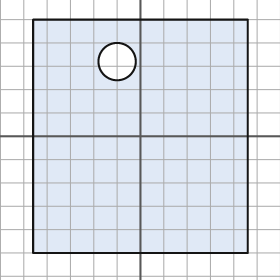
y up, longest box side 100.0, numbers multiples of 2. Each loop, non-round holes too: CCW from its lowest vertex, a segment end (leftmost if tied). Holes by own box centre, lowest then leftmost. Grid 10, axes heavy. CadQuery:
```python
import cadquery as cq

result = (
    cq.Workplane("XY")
    .moveTo(-46.0, -50.0)
    .lineTo(46.0, -50.0)
    .lineTo(46.0, 50.0)
    .lineTo(-46.0, 50.0)
    .close()
    .moveTo(-10.0, 32.0)
    .circle(8.0)
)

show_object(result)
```